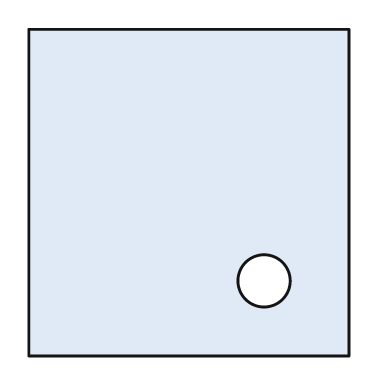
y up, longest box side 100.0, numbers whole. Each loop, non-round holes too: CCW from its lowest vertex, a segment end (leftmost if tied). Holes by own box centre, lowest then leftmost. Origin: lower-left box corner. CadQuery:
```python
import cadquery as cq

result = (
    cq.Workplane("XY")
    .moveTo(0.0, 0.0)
    .lineTo(98.0, 0.0)
    .lineTo(98.0, 100.0)
    .lineTo(0.0, 100.0)
    .close()
    .moveTo(72.0, 23.0)
    .circle(8.0)
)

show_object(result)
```